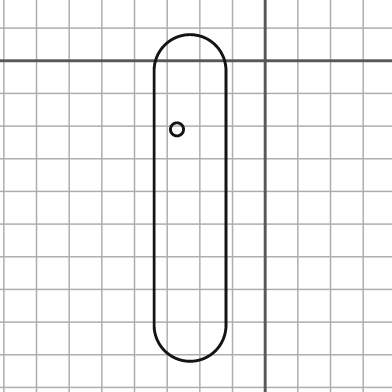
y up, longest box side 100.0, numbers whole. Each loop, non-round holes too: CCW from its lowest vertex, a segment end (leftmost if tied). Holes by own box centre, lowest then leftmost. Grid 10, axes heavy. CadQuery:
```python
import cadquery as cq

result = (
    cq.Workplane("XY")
    .moveTo(-34.0, -81.0)
    .threePointArc((-23.0, -92.0), (-12.0, -81.0))
    .lineTo(-12.0, -3.0)
    .threePointArc((-23.0, 8.0), (-34.0, -3.0))
    .close()
    .moveTo(-27.0, -21.0)
    .circle(2.0)
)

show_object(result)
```